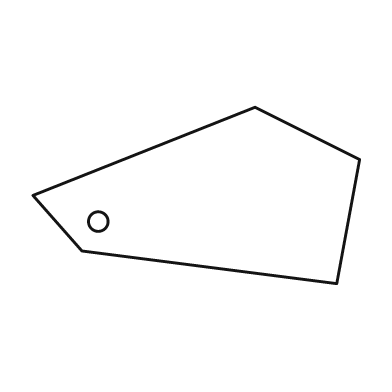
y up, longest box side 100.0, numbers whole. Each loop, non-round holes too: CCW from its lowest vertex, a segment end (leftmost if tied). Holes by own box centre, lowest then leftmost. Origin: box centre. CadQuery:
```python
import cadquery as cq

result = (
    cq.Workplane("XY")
    .moveTo(43.0, -27.0)
    .lineTo(50.0, 11.0)
    .lineTo(18.0, 27.0)
    .lineTo(-50.0, 0.0)
    .lineTo(-35.0, -17.0)
    .close()
    .moveTo(-30.0, -8.0)
    .circle(3.0)
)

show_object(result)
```